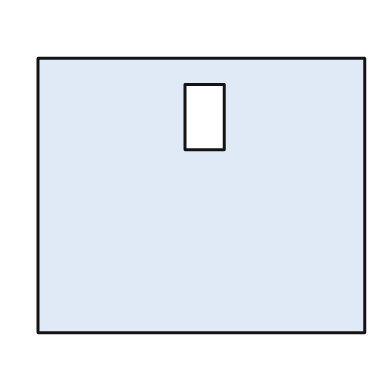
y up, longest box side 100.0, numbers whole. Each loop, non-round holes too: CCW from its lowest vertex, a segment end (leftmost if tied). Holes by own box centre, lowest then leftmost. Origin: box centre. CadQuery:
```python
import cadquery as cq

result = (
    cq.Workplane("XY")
    .moveTo(-50.0, -42.0)
    .lineTo(50.0, -42.0)
    .lineTo(50.0, 42.0)
    .lineTo(-50.0, 42.0)
    .close()
    .moveTo(-5.0, 14.0)
    .lineTo(7.0, 14.0)
    .lineTo(7.0, 34.0)
    .lineTo(-5.0, 34.0)
    .close()
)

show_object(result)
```